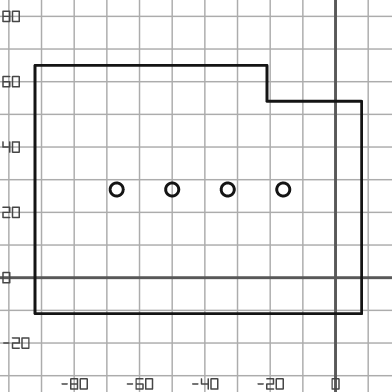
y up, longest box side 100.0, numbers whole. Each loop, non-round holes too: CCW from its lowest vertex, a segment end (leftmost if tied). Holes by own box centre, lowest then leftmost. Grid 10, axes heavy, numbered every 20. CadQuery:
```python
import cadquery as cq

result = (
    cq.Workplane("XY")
    .moveTo(-92.0, -11.0)
    .lineTo(8.0, -11.0)
    .lineTo(8.0, 54.0)
    .lineTo(-21.0, 54.0)
    .lineTo(-21.0, 65.0)
    .lineTo(-92.0, 65.0)
    .close()
    .moveTo(-67.0, 27.0)
    .circle(2.0)
    .moveTo(-50.0, 27.0)
    .circle(2.0)
    .moveTo(-33.0, 27.0)
    .circle(2.0)
    .moveTo(-16.0, 27.0)
    .circle(2.0)
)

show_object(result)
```